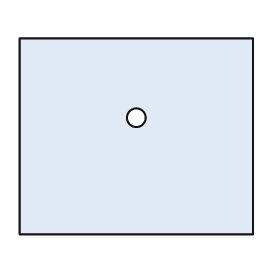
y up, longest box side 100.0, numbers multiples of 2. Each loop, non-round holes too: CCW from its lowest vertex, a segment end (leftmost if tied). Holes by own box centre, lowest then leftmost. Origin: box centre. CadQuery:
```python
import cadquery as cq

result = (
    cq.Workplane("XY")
    .moveTo(-50.0, -42.0)
    .lineTo(50.0, -42.0)
    .lineTo(50.0, 42.0)
    .lineTo(-50.0, 42.0)
    .close()
    .moveTo(0.0, 8.0)
    .circle(4.0)
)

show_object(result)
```